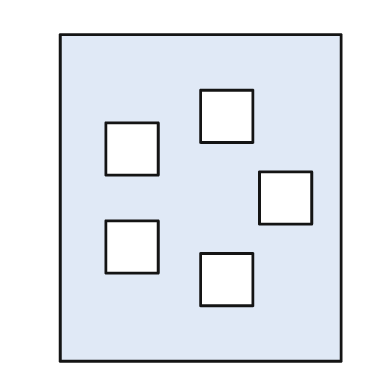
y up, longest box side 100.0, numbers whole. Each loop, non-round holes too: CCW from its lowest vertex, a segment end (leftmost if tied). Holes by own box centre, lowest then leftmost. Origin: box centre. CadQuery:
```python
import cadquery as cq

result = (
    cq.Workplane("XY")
    .moveTo(-43.0, -50.0)
    .lineTo(43.0, -50.0)
    .lineTo(43.0, 50.0)
    .lineTo(-43.0, 50.0)
    .close()
    .moveTo(0.0, -33.0)
    .lineTo(16.0, -33.0)
    .lineTo(16.0, -17.0)
    .lineTo(0.0, -17.0)
    .close()
    .moveTo(-29.0, -23.0)
    .lineTo(-13.0, -23.0)
    .lineTo(-13.0, -7.0)
    .lineTo(-29.0, -7.0)
    .close()
    .moveTo(18.0, -8.0)
    .lineTo(34.0, -8.0)
    .lineTo(34.0, 8.0)
    .lineTo(18.0, 8.0)
    .close()
    .moveTo(-29.0, 7.0)
    .lineTo(-13.0, 7.0)
    .lineTo(-13.0, 23.0)
    .lineTo(-29.0, 23.0)
    .close()
    .moveTo(0.0, 17.0)
    .lineTo(16.0, 17.0)
    .lineTo(16.0, 33.0)
    .lineTo(0.0, 33.0)
    .close()
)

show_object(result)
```